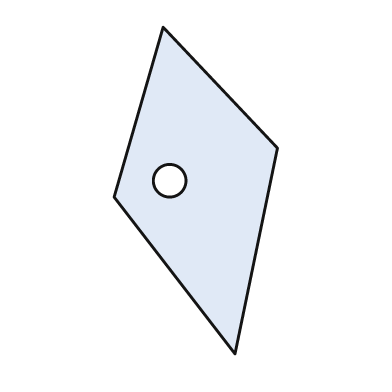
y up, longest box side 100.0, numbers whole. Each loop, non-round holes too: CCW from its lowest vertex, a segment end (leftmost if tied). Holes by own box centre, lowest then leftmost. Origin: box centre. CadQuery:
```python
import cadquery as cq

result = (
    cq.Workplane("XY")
    .moveTo(12.0, -50.0)
    .lineTo(25.0, 13.0)
    .lineTo(-10.0, 50.0)
    .lineTo(-25.0, -2.0)
    .close()
    .moveTo(-8.0, 3.0)
    .circle(5.0)
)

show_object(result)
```